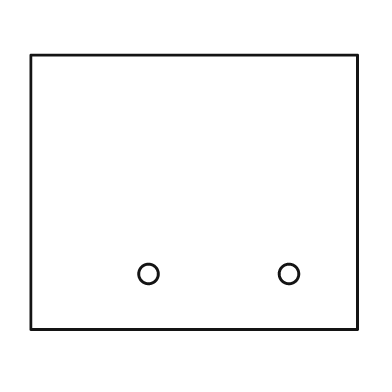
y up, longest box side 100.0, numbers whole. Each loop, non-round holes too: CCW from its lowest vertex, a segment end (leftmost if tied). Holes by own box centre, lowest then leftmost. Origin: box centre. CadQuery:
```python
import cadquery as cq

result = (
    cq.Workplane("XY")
    .moveTo(-50.0, -42.0)
    .lineTo(50.0, -42.0)
    .lineTo(50.0, 42.0)
    .lineTo(-50.0, 42.0)
    .close()
    .moveTo(-14.0, -25.0)
    .circle(3.0)
    .moveTo(29.0, -25.0)
    .circle(3.0)
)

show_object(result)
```